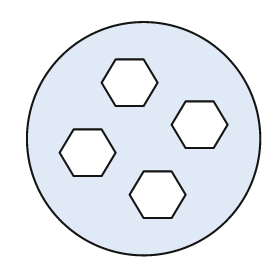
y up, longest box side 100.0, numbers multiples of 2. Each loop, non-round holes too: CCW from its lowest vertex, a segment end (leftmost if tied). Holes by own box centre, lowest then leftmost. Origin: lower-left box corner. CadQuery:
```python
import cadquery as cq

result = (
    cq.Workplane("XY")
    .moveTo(50.0, 50.0)
    .circle(50.0)
    .moveTo(50.0, 16.0)
    .lineTo(62.0, 16.0)
    .lineTo(68.0, 26.0)
    .lineTo(62.0, 36.0)
    .lineTo(50.0, 36.0)
    .lineTo(44.0, 26.0)
    .close()
    .moveTo(20.0, 34.0)
    .lineTo(32.0, 34.0)
    .lineTo(38.0, 44.0)
    .lineTo(32.0, 54.0)
    .lineTo(20.0, 54.0)
    .lineTo(14.0, 44.0)
    .close()
    .moveTo(68.0, 46.0)
    .lineTo(80.0, 46.0)
    .lineTo(86.0, 56.0)
    .lineTo(80.0, 66.0)
    .lineTo(68.0, 66.0)
    .lineTo(62.0, 56.0)
    .close()
    .moveTo(38.0, 64.0)
    .lineTo(50.0, 64.0)
    .lineTo(56.0, 74.0)
    .lineTo(50.0, 84.0)
    .lineTo(38.0, 84.0)
    .lineTo(32.0, 74.0)
    .close()
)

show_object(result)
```